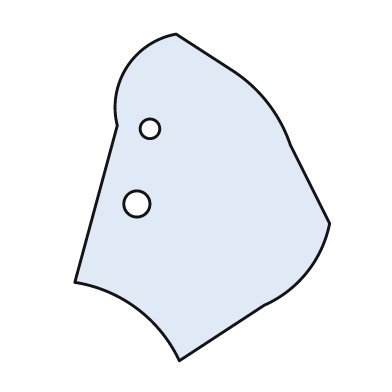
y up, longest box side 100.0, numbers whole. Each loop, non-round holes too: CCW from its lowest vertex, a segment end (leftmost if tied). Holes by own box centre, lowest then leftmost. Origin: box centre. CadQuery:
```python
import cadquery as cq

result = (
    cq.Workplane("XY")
    .moveTo(-7.0, -50.0)
    .lineTo(19.0, -33.0)
    .threePointArc((32.0, -23.0), (39.0, -8.0))
    .lineTo(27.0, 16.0)
    .threePointArc((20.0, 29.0), (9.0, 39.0))
    .lineTo(-8.0, 50.0)
    .threePointArc((-23.0, 40.0), (-26.0, 22.0))
    .lineTo(-39.0, -26.0)
    .threePointArc((-20.0, -34.0), (-7.0, -50.0))
    .close()
    .moveTo(-20.0, -2.0)
    .circle(4.0)
    .moveTo(-16.0, 21.0)
    .circle(3.0)
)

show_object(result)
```